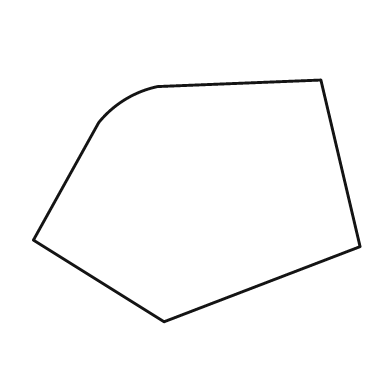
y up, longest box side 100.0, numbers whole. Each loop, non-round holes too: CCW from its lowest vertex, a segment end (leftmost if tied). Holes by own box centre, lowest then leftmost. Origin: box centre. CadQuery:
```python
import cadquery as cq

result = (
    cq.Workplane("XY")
    .moveTo(-10.0, -37.0)
    .lineTo(50.0, -14.0)
    .lineTo(38.0, 37.0)
    .lineTo(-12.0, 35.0)
    .threePointArc((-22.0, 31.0), (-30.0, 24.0))
    .lineTo(-50.0, -12.0)
    .close()
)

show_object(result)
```